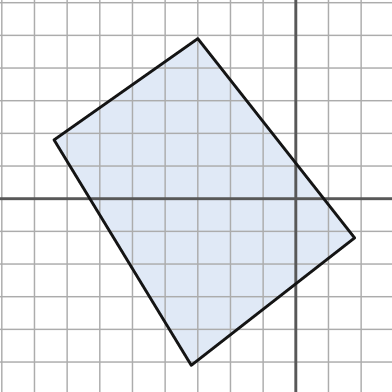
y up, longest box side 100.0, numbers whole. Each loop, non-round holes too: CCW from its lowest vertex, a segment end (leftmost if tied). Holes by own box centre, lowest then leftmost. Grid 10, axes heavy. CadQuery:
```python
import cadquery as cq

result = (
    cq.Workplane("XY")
    .moveTo(-32.0, -51.0)
    .lineTo(18.0, -12.0)
    .lineTo(-30.0, 49.0)
    .lineTo(-74.0, 18.0)
    .close()
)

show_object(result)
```